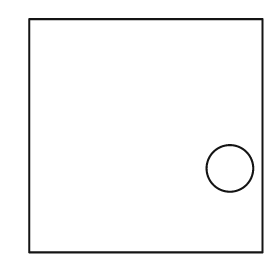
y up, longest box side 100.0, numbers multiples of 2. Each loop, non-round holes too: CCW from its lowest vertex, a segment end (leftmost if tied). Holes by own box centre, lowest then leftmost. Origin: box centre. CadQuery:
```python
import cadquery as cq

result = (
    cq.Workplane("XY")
    .moveTo(-50.0, -50.0)
    .lineTo(50.0, -50.0)
    .lineTo(50.0, 50.0)
    .lineTo(-50.0, 50.0)
    .close()
    .moveTo(36.0, -14.0)
    .circle(10.0)
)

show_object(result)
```